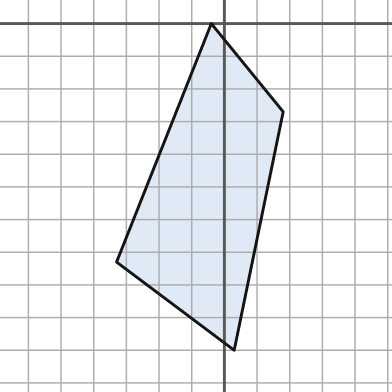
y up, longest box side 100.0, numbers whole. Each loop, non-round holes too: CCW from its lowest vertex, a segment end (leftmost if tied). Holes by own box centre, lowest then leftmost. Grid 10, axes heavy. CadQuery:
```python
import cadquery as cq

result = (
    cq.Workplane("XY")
    .moveTo(3.0, -100.0)
    .lineTo(18.0, -27.0)
    .lineTo(-4.0, 0.0)
    .lineTo(-33.0, -73.0)
    .close()
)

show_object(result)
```